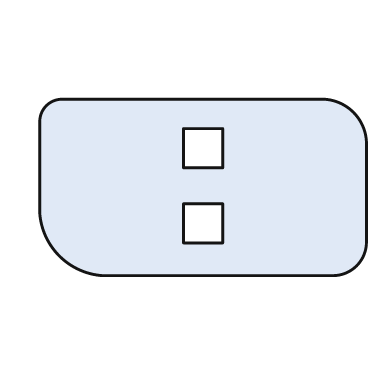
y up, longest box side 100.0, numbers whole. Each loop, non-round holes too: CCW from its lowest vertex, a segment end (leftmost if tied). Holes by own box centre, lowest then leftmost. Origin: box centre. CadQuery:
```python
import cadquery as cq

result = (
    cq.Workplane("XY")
    .moveTo(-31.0, -27.0)
    .lineTo(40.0, -27.0)
    .threePointArc((47.0, -24.0), (50.0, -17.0))
    .lineTo(50.0, 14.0)
    .threePointArc((46.0, 23.0), (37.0, 27.0))
    .lineTo(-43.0, 27.0)
    .threePointArc((-48.0, 25.0), (-50.0, 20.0))
    .lineTo(-50.0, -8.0)
    .threePointArc((-44.0, -21.0), (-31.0, -27.0))
    .close()
    .moveTo(-6.0, -17.0)
    .lineTo(6.0, -17.0)
    .lineTo(6.0, -5.0)
    .lineTo(-6.0, -5.0)
    .close()
    .moveTo(-6.0, 6.0)
    .lineTo(6.0, 6.0)
    .lineTo(6.0, 18.0)
    .lineTo(-6.0, 18.0)
    .close()
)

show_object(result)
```